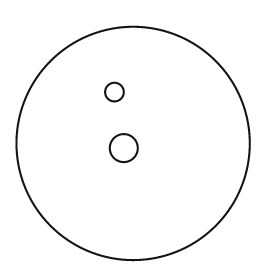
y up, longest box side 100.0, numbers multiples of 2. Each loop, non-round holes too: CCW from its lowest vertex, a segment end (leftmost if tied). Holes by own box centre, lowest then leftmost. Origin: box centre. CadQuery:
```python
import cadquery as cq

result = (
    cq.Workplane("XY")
    .moveTo(0.0, 0.0)
    .circle(50.0)
    .moveTo(-4.0, -2.0)
    .circle(6.0)
    .moveTo(-8.0, 22.0)
    .circle(4.0)
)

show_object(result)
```